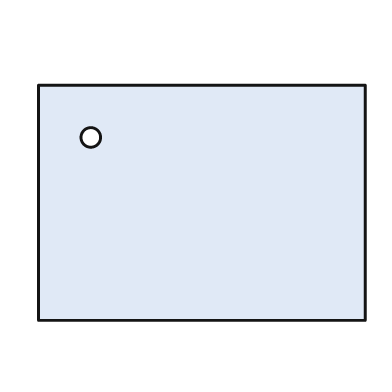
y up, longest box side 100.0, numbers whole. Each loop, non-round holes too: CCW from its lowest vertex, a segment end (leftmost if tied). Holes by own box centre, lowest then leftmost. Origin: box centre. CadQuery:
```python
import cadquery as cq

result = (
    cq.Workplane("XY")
    .moveTo(-50.0, -36.0)
    .lineTo(50.0, -36.0)
    .lineTo(50.0, 36.0)
    .lineTo(-50.0, 36.0)
    .close()
    .moveTo(-34.0, 20.0)
    .circle(3.0)
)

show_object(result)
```